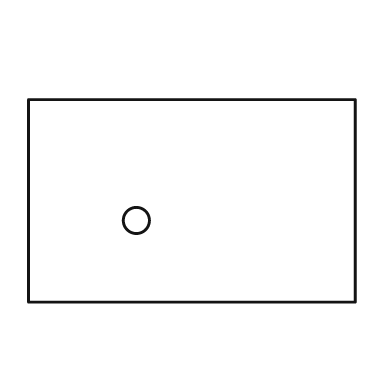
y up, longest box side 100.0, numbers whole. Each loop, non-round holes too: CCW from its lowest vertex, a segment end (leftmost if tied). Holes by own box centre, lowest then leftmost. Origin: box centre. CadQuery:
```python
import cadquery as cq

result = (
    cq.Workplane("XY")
    .moveTo(-50.0, -31.0)
    .lineTo(50.0, -31.0)
    .lineTo(50.0, 31.0)
    .lineTo(-50.0, 31.0)
    .close()
    .moveTo(-17.0, -6.0)
    .circle(4.0)
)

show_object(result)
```